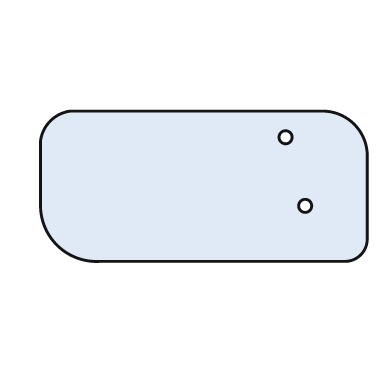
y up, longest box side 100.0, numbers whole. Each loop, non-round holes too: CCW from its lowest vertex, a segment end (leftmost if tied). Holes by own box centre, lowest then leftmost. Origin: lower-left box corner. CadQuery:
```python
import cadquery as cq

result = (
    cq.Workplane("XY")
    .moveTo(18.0, 0.0)
    .lineTo(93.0, 0.0)
    .threePointArc((98.0, 2.0), (100.0, 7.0))
    .lineTo(100.0, 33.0)
    .threePointArc((96.0, 42.0), (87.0, 46.0))
    .lineTo(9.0, 46.0)
    .threePointArc((3.0, 43.0), (0.0, 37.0))
    .lineTo(0.0, 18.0)
    .threePointArc((5.0, 5.0), (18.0, 0.0))
    .close()
    .moveTo(81.0, 17.0)
    .circle(2.0)
    .moveTo(75.0, 38.0)
    .circle(2.0)
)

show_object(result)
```